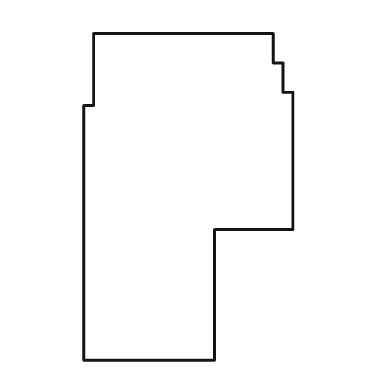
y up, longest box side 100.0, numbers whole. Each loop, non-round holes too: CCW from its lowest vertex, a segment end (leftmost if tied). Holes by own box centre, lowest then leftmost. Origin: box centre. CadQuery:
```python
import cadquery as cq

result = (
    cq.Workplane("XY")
    .moveTo(-32.0, -50.0)
    .lineTo(8.0, -50.0)
    .lineTo(8.0, -10.0)
    .lineTo(32.0, -10.0)
    .lineTo(32.0, 32.0)
    .lineTo(29.0, 32.0)
    .lineTo(29.0, 41.0)
    .lineTo(26.0, 41.0)
    .lineTo(26.0, 50.0)
    .lineTo(-29.0, 50.0)
    .lineTo(-29.0, 28.0)
    .lineTo(-32.0, 28.0)
    .close()
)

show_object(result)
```